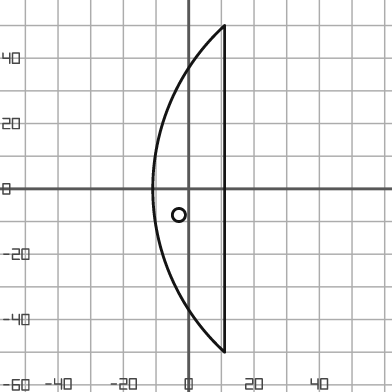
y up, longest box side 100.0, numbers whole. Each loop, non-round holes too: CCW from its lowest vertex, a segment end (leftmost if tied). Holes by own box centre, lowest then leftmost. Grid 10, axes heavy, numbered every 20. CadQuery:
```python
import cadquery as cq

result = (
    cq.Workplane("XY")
    .moveTo(11.0, -50.0)
    .lineTo(11.0, 50.0)
    .threePointArc((-11.0, 0.0), (11.0, -50.0))
    .close()
    .moveTo(-3.0, -8.0)
    .circle(2.0)
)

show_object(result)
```